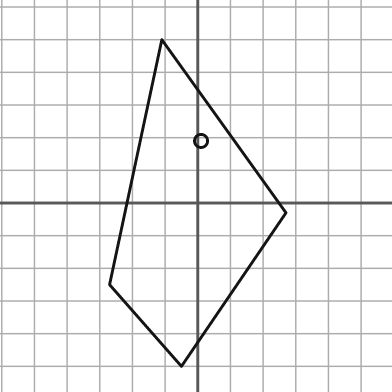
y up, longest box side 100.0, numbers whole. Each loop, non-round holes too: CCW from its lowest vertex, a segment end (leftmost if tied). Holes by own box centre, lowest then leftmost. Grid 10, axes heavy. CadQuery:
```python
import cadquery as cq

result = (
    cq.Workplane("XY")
    .moveTo(-5.0, -50.0)
    .lineTo(27.0, -3.0)
    .lineTo(-11.0, 50.0)
    .lineTo(-27.0, -25.0)
    .close()
    .moveTo(1.0, 19.0)
    .circle(2.0)
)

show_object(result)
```